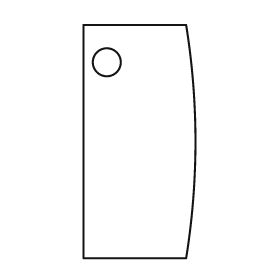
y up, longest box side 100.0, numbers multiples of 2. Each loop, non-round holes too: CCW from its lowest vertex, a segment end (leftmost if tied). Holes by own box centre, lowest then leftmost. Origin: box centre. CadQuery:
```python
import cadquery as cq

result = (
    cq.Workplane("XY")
    .moveTo(-24.0, -50.0)
    .lineTo(20.0, -50.0)
    .threePointArc((24.0, 0.0), (20.0, 50.0))
    .lineTo(-24.0, 50.0)
    .close()
    .moveTo(-14.0, 34.0)
    .circle(6.0)
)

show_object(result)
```